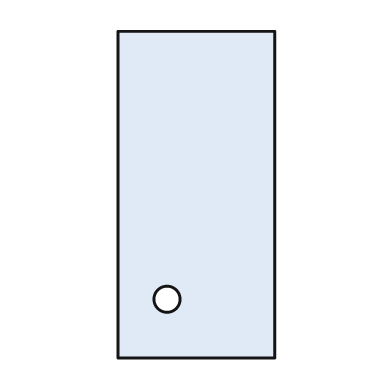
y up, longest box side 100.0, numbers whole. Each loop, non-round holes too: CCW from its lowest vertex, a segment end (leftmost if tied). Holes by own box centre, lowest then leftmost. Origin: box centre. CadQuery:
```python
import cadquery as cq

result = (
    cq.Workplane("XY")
    .moveTo(-24.0, -50.0)
    .lineTo(24.0, -50.0)
    .lineTo(24.0, 50.0)
    .lineTo(-24.0, 50.0)
    .close()
    .moveTo(-9.0, -32.0)
    .circle(4.0)
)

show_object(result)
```